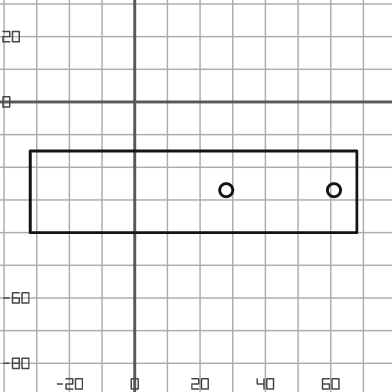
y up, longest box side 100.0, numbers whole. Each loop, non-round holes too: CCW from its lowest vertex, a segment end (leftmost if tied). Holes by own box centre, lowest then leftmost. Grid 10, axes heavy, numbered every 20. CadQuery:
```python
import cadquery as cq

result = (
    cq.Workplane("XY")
    .moveTo(-32.0, -40.0)
    .lineTo(68.0, -40.0)
    .lineTo(68.0, -15.0)
    .lineTo(-32.0, -15.0)
    .close()
    .moveTo(28.0, -27.0)
    .circle(2.0)
    .moveTo(61.0, -27.0)
    .circle(2.0)
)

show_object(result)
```